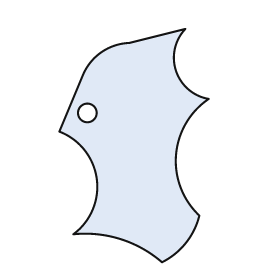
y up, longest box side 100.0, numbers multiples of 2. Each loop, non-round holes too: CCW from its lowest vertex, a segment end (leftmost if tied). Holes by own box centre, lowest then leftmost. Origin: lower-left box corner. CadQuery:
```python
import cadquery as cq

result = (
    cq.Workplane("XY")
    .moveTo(44.0, 0.0)
    .threePointArc((54.0, 8.0), (60.0, 20.0))
    .threePointArc((50.0, 46.0), (64.0, 70.0))
    .threePointArc((50.0, 82.0), (54.0, 100.0))
    .lineTo(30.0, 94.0)
    .threePointArc((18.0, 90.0), (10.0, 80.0))
    .lineTo(0.0, 56.0)
    .threePointArc((16.0, 36.0), (6.0, 12.0))
    .threePointArc((26.0, 10.0), (44.0, 0.0))
    .close()
    .moveTo(12.0, 64.0)
    .circle(4.0)
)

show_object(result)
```